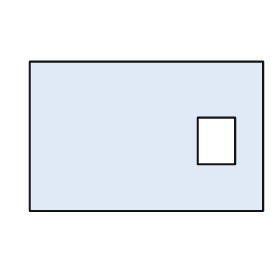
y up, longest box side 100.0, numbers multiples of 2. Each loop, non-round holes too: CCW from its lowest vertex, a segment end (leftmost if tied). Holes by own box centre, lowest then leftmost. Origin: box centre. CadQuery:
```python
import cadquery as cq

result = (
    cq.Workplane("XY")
    .moveTo(-50.0, -32.0)
    .lineTo(50.0, -32.0)
    .lineTo(50.0, 32.0)
    .lineTo(-50.0, 32.0)
    .close()
    .moveTo(22.0, -12.0)
    .lineTo(38.0, -12.0)
    .lineTo(38.0, 8.0)
    .lineTo(22.0, 8.0)
    .close()
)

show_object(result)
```